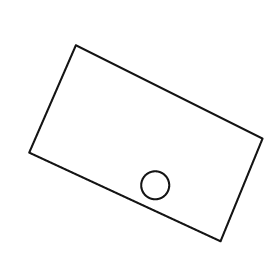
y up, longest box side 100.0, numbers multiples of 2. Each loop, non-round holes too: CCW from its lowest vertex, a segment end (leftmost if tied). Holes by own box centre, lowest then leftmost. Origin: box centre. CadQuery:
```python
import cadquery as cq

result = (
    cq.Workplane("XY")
    .moveTo(32.0, -42.0)
    .lineTo(50.0, 2.0)
    .lineTo(-30.0, 42.0)
    .lineTo(-50.0, -4.0)
    .close()
    .moveTo(4.0, -18.0)
    .circle(6.0)
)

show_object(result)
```